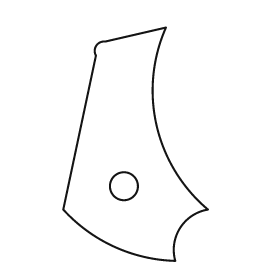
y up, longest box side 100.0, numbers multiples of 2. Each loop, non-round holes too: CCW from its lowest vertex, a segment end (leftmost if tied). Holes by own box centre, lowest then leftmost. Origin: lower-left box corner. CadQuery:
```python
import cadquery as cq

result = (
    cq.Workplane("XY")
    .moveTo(48.0, 0.0)
    .threePointArc((50.0, 14.0), (62.0, 22.0))
    .threePointArc((40.0, 58.0), (44.0, 100.0))
    .lineTo(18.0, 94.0)
    .threePointArc((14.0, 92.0), (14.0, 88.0))
    .lineTo(0.0, 22.0)
    .threePointArc((22.0, 6.0), (48.0, 0.0))
    .close()
    .moveTo(26.0, 32.0)
    .circle(6.0)
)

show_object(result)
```